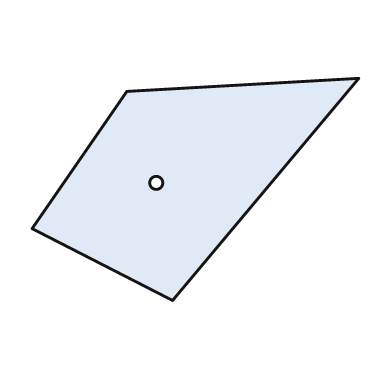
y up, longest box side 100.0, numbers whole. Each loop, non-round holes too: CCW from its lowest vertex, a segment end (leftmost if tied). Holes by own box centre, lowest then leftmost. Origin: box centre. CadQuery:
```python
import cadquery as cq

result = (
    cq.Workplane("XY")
    .moveTo(-7.0, -34.0)
    .lineTo(50.0, 34.0)
    .lineTo(-21.0, 30.0)
    .lineTo(-50.0, -12.0)
    .close()
    .moveTo(-12.0, 2.0)
    .circle(2.0)
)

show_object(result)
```